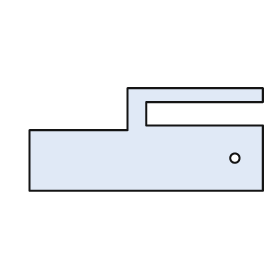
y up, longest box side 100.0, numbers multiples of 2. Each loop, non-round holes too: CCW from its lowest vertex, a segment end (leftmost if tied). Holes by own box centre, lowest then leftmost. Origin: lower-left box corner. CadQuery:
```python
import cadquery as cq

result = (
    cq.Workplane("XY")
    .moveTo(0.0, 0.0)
    .lineTo(100.0, 0.0)
    .lineTo(100.0, 28.0)
    .lineTo(50.0, 28.0)
    .lineTo(50.0, 38.0)
    .lineTo(100.0, 38.0)
    .lineTo(100.0, 44.0)
    .lineTo(42.0, 44.0)
    .lineTo(42.0, 26.0)
    .lineTo(0.0, 26.0)
    .close()
    .moveTo(88.0, 14.0)
    .circle(2.0)
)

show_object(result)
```